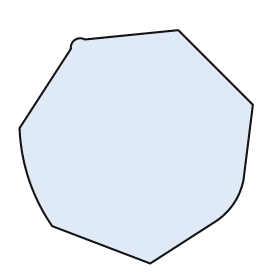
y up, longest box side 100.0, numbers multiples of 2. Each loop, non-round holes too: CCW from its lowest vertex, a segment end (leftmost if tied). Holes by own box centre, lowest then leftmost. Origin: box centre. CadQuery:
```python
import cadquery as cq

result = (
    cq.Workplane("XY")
    .moveTo(6.0, -50.0)
    .lineTo(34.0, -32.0)
    .threePointArc((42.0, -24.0), (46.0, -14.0))
    .lineTo(50.0, 18.0)
    .lineTo(18.0, 50.0)
    .lineTo(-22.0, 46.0)
    .threePointArc((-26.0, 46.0), (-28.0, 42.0))
    .lineTo(-50.0, 8.0)
    .threePointArc((-46.0, -14.0), (-36.0, -34.0))
    .close()
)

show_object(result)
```